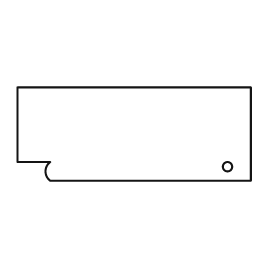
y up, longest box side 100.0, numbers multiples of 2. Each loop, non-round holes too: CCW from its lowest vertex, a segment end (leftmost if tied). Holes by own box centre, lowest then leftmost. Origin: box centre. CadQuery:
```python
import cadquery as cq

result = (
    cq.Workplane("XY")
    .moveTo(-36.0, -20.0)
    .lineTo(50.0, -20.0)
    .lineTo(50.0, 20.0)
    .lineTo(-50.0, 20.0)
    .lineTo(-50.0, -12.0)
    .lineTo(-36.0, -12.0)
    .threePointArc((-38.0, -16.0), (-36.0, -20.0))
    .close()
    .moveTo(40.0, -14.0)
    .circle(2.0)
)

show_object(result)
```